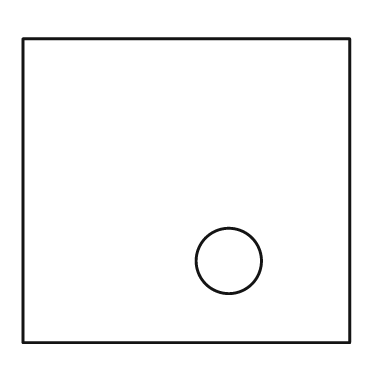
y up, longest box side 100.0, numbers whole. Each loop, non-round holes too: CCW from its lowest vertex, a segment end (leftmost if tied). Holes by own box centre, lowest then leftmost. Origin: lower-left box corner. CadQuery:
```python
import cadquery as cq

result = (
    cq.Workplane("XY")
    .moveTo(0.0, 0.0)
    .lineTo(100.0, 0.0)
    .lineTo(100.0, 93.0)
    .lineTo(0.0, 93.0)
    .close()
    .moveTo(63.0, 25.0)
    .circle(10.0)
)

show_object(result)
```